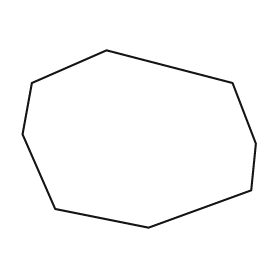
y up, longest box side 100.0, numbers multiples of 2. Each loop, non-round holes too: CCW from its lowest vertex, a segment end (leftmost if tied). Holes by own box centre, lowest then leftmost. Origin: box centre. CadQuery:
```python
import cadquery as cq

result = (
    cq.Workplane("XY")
    .moveTo(4.0, -38.0)
    .lineTo(48.0, -22.0)
    .lineTo(50.0, -2.0)
    .lineTo(40.0, 24.0)
    .lineTo(-14.0, 38.0)
    .lineTo(-46.0, 24.0)
    .lineTo(-50.0, 2.0)
    .lineTo(-36.0, -30.0)
    .close()
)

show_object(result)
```